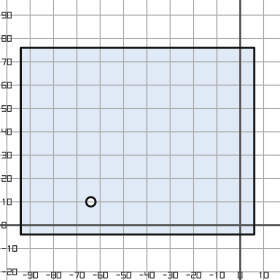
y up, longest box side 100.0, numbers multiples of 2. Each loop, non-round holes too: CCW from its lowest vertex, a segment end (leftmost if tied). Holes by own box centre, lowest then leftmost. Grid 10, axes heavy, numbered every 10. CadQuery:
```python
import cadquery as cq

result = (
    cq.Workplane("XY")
    .moveTo(-94.0, -4.0)
    .lineTo(6.0, -4.0)
    .lineTo(6.0, 76.0)
    .lineTo(-94.0, 76.0)
    .close()
    .moveTo(-64.0, 10.0)
    .circle(2.0)
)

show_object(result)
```